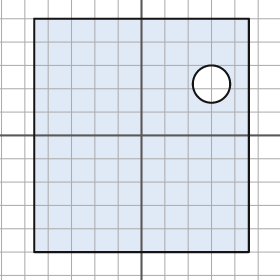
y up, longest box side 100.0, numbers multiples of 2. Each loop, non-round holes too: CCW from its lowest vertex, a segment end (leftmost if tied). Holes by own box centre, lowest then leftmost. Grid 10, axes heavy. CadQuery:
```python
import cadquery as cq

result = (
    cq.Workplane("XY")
    .moveTo(-46.0, -50.0)
    .lineTo(46.0, -50.0)
    .lineTo(46.0, 50.0)
    .lineTo(-46.0, 50.0)
    .close()
    .moveTo(30.0, 22.0)
    .circle(8.0)
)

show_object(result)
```